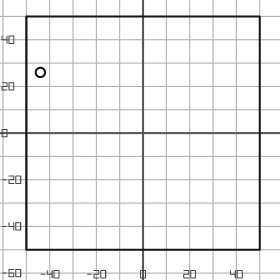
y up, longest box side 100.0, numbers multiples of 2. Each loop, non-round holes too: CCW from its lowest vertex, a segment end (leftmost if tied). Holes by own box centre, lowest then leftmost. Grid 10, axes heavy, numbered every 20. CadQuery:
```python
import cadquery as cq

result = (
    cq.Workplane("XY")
    .moveTo(-50.0, -50.0)
    .lineTo(50.0, -50.0)
    .lineTo(50.0, 50.0)
    .lineTo(-50.0, 50.0)
    .close()
    .moveTo(-44.0, 26.0)
    .circle(2.0)
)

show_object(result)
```